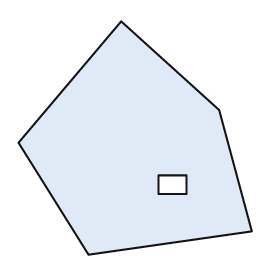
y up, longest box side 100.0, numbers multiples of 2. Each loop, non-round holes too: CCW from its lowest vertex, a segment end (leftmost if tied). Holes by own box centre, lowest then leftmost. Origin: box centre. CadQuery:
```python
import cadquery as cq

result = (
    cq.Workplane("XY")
    .moveTo(-20.0, -50.0)
    .lineTo(50.0, -40.0)
    .lineTo(36.0, 12.0)
    .lineTo(-6.0, 50.0)
    .lineTo(-50.0, -2.0)
    .close()
    .moveTo(10.0, -24.0)
    .lineTo(22.0, -24.0)
    .lineTo(22.0, -16.0)
    .lineTo(10.0, -16.0)
    .close()
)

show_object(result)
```